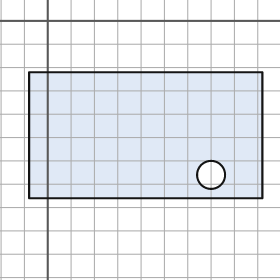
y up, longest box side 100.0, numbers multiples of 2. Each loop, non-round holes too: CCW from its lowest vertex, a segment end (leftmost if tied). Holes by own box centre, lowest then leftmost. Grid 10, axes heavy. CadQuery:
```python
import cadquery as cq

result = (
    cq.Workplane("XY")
    .moveTo(-8.0, -76.0)
    .lineTo(92.0, -76.0)
    .lineTo(92.0, -22.0)
    .lineTo(-8.0, -22.0)
    .close()
    .moveTo(70.0, -66.0)
    .circle(6.0)
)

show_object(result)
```